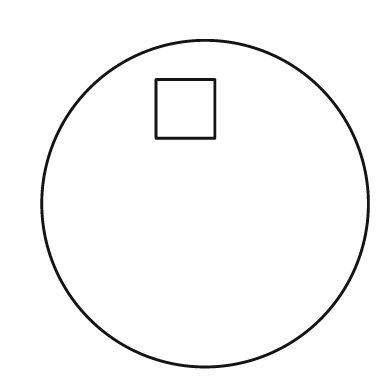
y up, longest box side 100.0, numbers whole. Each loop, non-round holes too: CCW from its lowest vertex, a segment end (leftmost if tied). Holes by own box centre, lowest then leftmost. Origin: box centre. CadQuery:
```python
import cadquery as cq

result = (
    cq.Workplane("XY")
    .moveTo(0.0, 0.0)
    .circle(50.0)
    .moveTo(-15.0, 20.0)
    .lineTo(3.0, 20.0)
    .lineTo(3.0, 38.0)
    .lineTo(-15.0, 38.0)
    .close()
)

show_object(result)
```